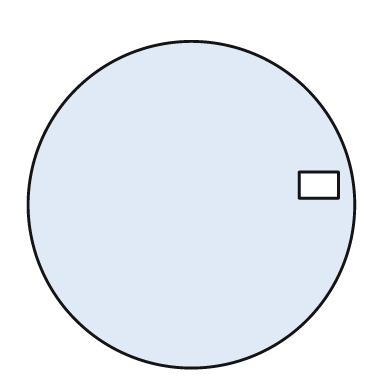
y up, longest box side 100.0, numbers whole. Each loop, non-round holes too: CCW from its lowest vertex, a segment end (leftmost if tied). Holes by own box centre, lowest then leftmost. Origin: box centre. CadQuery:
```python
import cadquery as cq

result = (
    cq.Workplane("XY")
    .moveTo(0.0, 0.0)
    .circle(50.0)
    .moveTo(33.0, 2.0)
    .lineTo(45.0, 2.0)
    .lineTo(45.0, 10.0)
    .lineTo(33.0, 10.0)
    .close()
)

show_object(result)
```